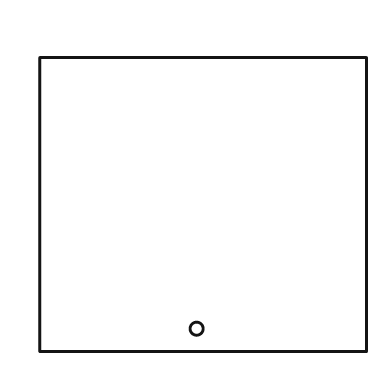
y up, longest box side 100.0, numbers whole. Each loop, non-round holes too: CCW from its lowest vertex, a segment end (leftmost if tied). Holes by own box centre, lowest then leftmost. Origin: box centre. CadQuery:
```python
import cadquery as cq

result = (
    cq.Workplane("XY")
    .moveTo(-50.0, -45.0)
    .lineTo(50.0, -45.0)
    .lineTo(50.0, 45.0)
    .lineTo(-50.0, 45.0)
    .close()
    .moveTo(-2.0, -38.0)
    .circle(2.0)
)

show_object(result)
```